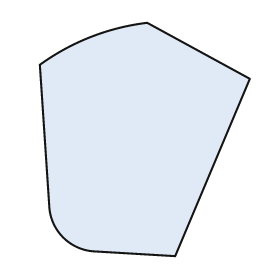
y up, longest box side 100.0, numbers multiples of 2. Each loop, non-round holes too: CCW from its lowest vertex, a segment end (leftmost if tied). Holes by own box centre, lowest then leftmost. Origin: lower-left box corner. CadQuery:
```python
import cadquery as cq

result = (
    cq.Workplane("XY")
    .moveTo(58.0, 0.0)
    .lineTo(90.0, 76.0)
    .lineTo(46.0, 100.0)
    .threePointArc((22.0, 94.0), (0.0, 82.0))
    .lineTo(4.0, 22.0)
    .threePointArc((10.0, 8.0), (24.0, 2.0))
    .close()
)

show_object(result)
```